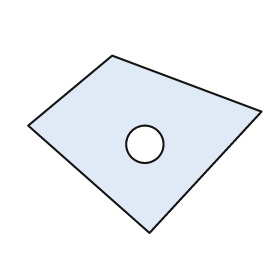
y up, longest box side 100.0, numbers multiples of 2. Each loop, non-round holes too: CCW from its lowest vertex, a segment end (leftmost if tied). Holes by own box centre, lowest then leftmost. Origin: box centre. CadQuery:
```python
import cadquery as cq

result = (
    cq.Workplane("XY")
    .moveTo(2.0, -38.0)
    .lineTo(50.0, 14.0)
    .lineTo(-14.0, 38.0)
    .lineTo(-50.0, 8.0)
    .close()
    .moveTo(0.0, 0.0)
    .circle(8.0)
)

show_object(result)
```